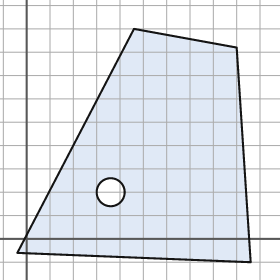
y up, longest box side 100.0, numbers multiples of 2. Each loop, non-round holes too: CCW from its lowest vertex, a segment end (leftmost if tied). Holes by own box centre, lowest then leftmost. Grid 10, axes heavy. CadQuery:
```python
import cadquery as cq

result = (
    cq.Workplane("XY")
    .moveTo(96.0, -10.0)
    .lineTo(90.0, 82.0)
    .lineTo(46.0, 90.0)
    .lineTo(-4.0, -6.0)
    .close()
    .moveTo(36.0, 20.0)
    .circle(6.0)
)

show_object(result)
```